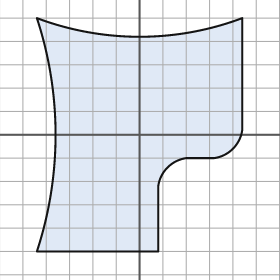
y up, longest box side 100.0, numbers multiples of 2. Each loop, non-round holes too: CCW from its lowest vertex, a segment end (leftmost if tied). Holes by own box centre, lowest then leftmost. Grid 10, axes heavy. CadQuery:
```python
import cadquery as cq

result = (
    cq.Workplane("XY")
    .moveTo(-44.0, -50.0)
    .lineTo(8.0, -50.0)
    .lineTo(8.0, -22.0)
    .threePointArc((12.0, -14.0), (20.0, -10.0))
    .lineTo(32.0, -10.0)
    .threePointArc((40.0, -6.0), (44.0, 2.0))
    .lineTo(44.0, 50.0)
    .threePointArc((0.0, 42.0), (-44.0, 50.0))
    .threePointArc((-36.0, 0.0), (-44.0, -50.0))
    .close()
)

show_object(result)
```